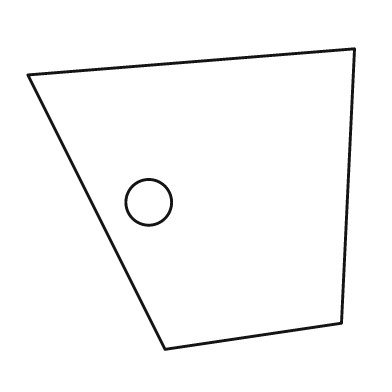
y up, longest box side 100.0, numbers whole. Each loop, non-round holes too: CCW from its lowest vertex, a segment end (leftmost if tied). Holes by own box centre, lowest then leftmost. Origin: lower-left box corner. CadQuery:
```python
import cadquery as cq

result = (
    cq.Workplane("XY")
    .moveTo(42.0, 0.0)
    .lineTo(96.0, 8.0)
    .lineTo(100.0, 92.0)
    .lineTo(0.0, 84.0)
    .close()
    .moveTo(37.0, 45.0)
    .circle(7.0)
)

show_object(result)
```